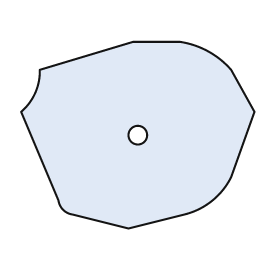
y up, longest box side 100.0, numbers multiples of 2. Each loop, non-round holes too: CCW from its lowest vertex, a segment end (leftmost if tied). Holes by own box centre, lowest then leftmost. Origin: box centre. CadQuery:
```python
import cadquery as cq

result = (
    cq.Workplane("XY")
    .moveTo(-4.0, -40.0)
    .lineTo(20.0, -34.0)
    .threePointArc((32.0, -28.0), (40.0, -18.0))
    .lineTo(50.0, 10.0)
    .lineTo(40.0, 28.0)
    .threePointArc((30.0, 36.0), (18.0, 40.0))
    .lineTo(-2.0, 40.0)
    .lineTo(-42.0, 28.0)
    .threePointArc((-44.0, 18.0), (-50.0, 10.0))
    .lineTo(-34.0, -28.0)
    .threePointArc((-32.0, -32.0), (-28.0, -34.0))
    .close()
    .moveTo(0.0, 0.0)
    .circle(4.0)
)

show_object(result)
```